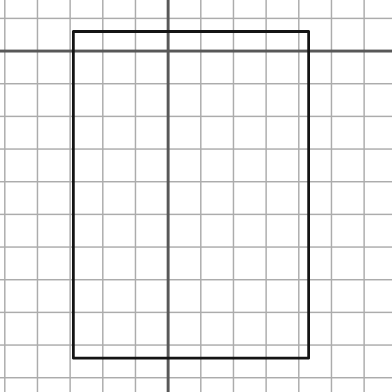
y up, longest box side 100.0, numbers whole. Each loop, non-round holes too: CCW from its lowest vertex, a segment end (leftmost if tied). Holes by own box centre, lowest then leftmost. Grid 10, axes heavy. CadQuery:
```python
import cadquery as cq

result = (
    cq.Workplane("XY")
    .moveTo(-29.0, -94.0)
    .lineTo(43.0, -94.0)
    .lineTo(43.0, 6.0)
    .lineTo(-29.0, 6.0)
    .close()
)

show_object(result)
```